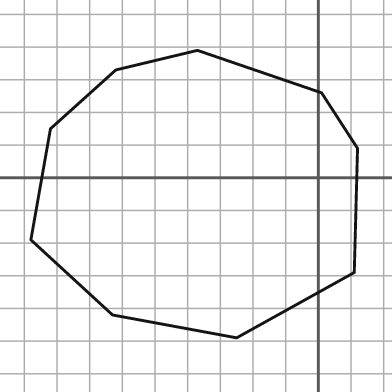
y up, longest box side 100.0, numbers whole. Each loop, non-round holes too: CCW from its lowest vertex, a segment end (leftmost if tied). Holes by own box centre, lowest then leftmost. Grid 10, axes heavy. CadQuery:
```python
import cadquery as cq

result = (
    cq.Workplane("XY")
    .moveTo(-25.0, -49.0)
    .lineTo(11.0, -29.0)
    .lineTo(12.0, 9.0)
    .lineTo(1.0, 26.0)
    .lineTo(-37.0, 39.0)
    .lineTo(-62.0, 33.0)
    .lineTo(-82.0, 15.0)
    .lineTo(-88.0, -19.0)
    .lineTo(-63.0, -42.0)
    .close()
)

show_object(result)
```